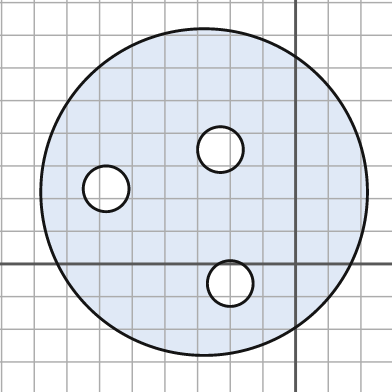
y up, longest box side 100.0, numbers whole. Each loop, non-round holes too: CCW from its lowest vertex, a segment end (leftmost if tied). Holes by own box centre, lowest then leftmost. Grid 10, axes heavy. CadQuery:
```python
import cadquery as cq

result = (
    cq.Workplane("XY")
    .moveTo(-28.0, 22.0)
    .circle(50.0)
    .moveTo(-20.0, -6.0)
    .circle(7.0)
    .moveTo(-58.0, 23.0)
    .circle(7.0)
    .moveTo(-23.0, 35.0)
    .circle(7.0)
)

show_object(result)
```